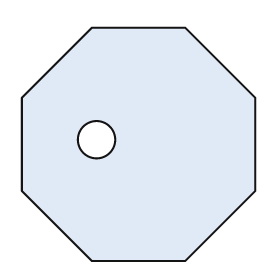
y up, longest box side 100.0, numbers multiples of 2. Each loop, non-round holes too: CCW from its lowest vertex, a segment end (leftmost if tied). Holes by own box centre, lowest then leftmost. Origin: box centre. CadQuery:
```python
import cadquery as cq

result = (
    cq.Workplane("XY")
    .moveTo(-20.0, -50.0)
    .lineTo(20.0, -50.0)
    .lineTo(50.0, -20.0)
    .lineTo(50.0, 20.0)
    .lineTo(20.0, 50.0)
    .lineTo(-20.0, 50.0)
    .lineTo(-50.0, 20.0)
    .lineTo(-50.0, -20.0)
    .close()
    .moveTo(-18.0, 2.0)
    .circle(8.0)
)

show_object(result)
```